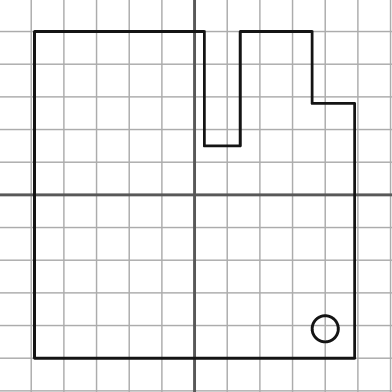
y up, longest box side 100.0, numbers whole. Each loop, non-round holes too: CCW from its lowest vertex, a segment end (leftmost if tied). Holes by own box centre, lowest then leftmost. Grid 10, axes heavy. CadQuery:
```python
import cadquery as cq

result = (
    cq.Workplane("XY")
    .moveTo(-49.0, -50.0)
    .lineTo(49.0, -50.0)
    .lineTo(49.0, 28.0)
    .lineTo(36.0, 28.0)
    .lineTo(36.0, 50.0)
    .lineTo(14.0, 50.0)
    .lineTo(14.0, 15.0)
    .lineTo(3.0, 15.0)
    .lineTo(3.0, 50.0)
    .lineTo(-49.0, 50.0)
    .close()
    .moveTo(40.0, -41.0)
    .circle(4.0)
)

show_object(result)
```